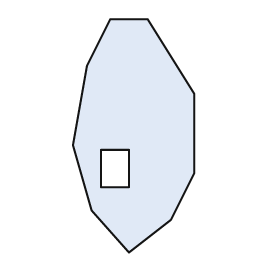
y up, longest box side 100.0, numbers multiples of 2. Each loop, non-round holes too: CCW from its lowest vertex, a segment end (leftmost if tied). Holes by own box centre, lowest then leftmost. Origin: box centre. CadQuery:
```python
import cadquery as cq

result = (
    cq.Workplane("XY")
    .moveTo(-2.0, -50.0)
    .lineTo(16.0, -36.0)
    .lineTo(26.0, -16.0)
    .lineTo(26.0, 18.0)
    .lineTo(6.0, 50.0)
    .lineTo(-10.0, 50.0)
    .lineTo(-20.0, 30.0)
    .lineTo(-26.0, -4.0)
    .lineTo(-18.0, -32.0)
    .close()
    .moveTo(-14.0, -22.0)
    .lineTo(-2.0, -22.0)
    .lineTo(-2.0, -6.0)
    .lineTo(-14.0, -6.0)
    .close()
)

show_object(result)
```